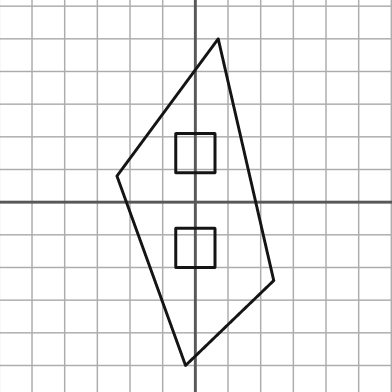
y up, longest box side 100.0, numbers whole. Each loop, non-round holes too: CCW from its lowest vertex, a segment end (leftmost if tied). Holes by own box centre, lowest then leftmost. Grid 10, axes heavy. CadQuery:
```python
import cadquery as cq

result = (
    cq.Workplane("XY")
    .moveTo(-3.0, -50.0)
    .lineTo(24.0, -24.0)
    .lineTo(7.0, 50.0)
    .lineTo(-24.0, 8.0)
    .close()
    .moveTo(-6.0, -20.0)
    .lineTo(6.0, -20.0)
    .lineTo(6.0, -8.0)
    .lineTo(-6.0, -8.0)
    .close()
    .moveTo(-6.0, 9.0)
    .lineTo(6.0, 9.0)
    .lineTo(6.0, 21.0)
    .lineTo(-6.0, 21.0)
    .close()
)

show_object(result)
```